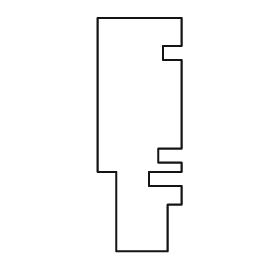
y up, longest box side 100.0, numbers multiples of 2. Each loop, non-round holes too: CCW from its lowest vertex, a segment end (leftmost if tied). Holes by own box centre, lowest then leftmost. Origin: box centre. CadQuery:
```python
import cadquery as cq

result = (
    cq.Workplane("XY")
    .moveTo(-10.0, -50.0)
    .lineTo(12.0, -50.0)
    .lineTo(12.0, -30.0)
    .lineTo(18.0, -30.0)
    .lineTo(18.0, -22.0)
    .lineTo(4.0, -22.0)
    .lineTo(4.0, -16.0)
    .lineTo(18.0, -16.0)
    .lineTo(18.0, -12.0)
    .lineTo(8.0, -12.0)
    .lineTo(8.0, -6.0)
    .lineTo(18.0, -6.0)
    .lineTo(18.0, 32.0)
    .lineTo(10.0, 32.0)
    .lineTo(10.0, 38.0)
    .lineTo(18.0, 38.0)
    .lineTo(18.0, 50.0)
    .lineTo(-18.0, 50.0)
    .lineTo(-18.0, -16.0)
    .lineTo(-10.0, -16.0)
    .close()
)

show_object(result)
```